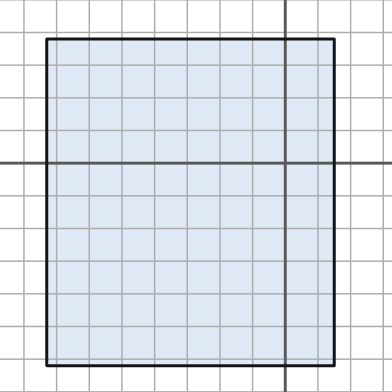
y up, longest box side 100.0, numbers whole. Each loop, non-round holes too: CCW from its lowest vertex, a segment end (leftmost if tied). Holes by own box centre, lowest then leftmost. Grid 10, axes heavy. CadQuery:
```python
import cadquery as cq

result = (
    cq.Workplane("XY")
    .moveTo(-73.0, -62.0)
    .lineTo(15.0, -62.0)
    .lineTo(15.0, 38.0)
    .lineTo(-73.0, 38.0)
    .close()
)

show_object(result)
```